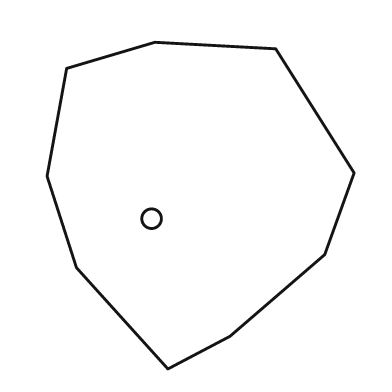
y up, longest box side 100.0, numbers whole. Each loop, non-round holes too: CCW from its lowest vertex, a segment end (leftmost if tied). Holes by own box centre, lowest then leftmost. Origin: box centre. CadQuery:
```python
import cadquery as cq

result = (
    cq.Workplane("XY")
    .moveTo(-10.0, -50.0)
    .lineTo(9.0, -40.0)
    .lineTo(38.0, -15.0)
    .lineTo(47.0, 10.0)
    .lineTo(23.0, 48.0)
    .lineTo(-14.0, 50.0)
    .lineTo(-41.0, 42.0)
    .lineTo(-47.0, 9.0)
    .lineTo(-38.0, -19.0)
    .close()
    .moveTo(-15.0, -4.0)
    .circle(3.0)
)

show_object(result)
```